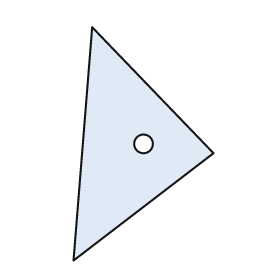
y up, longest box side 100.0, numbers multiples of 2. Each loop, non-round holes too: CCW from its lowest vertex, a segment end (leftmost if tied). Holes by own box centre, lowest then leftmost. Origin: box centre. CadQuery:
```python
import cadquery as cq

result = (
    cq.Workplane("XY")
    .moveTo(-30.0, -50.0)
    .lineTo(30.0, -4.0)
    .lineTo(-22.0, 50.0)
    .close()
    .moveTo(0.0, 0.0)
    .circle(4.0)
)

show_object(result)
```